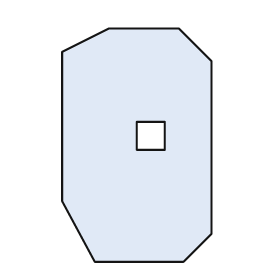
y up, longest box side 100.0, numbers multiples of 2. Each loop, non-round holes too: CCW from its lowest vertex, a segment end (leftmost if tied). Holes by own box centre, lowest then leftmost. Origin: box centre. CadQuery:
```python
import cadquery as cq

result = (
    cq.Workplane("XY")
    .moveTo(-18.0, -50.0)
    .lineTo(20.0, -50.0)
    .lineTo(32.0, -38.0)
    .lineTo(32.0, 36.0)
    .lineTo(18.0, 50.0)
    .lineTo(-12.0, 50.0)
    .lineTo(-32.0, 40.0)
    .lineTo(-32.0, -24.0)
    .close()
    .moveTo(0.0, -2.0)
    .lineTo(12.0, -2.0)
    .lineTo(12.0, 10.0)
    .lineTo(0.0, 10.0)
    .close()
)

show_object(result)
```